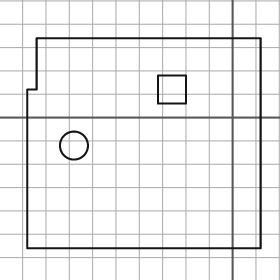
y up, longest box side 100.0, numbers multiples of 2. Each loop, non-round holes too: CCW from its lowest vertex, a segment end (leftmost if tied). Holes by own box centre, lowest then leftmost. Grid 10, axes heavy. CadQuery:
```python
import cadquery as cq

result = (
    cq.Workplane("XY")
    .moveTo(-88.0, -56.0)
    .lineTo(12.0, -56.0)
    .lineTo(12.0, 34.0)
    .lineTo(-84.0, 34.0)
    .lineTo(-84.0, 12.0)
    .lineTo(-88.0, 12.0)
    .close()
    .moveTo(-68.0, -12.0)
    .circle(6.0)
    .moveTo(-32.0, 6.0)
    .lineTo(-20.0, 6.0)
    .lineTo(-20.0, 18.0)
    .lineTo(-32.0, 18.0)
    .close()
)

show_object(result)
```